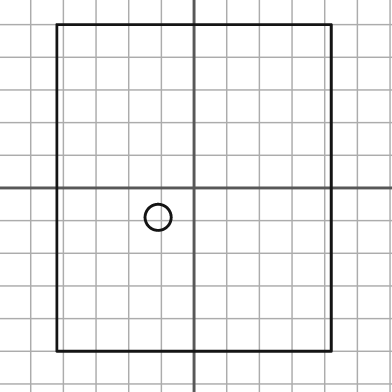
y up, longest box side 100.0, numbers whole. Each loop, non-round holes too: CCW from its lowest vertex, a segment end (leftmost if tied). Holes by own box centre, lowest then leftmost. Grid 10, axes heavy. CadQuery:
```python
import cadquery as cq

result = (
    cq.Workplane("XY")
    .moveTo(-42.0, -50.0)
    .lineTo(42.0, -50.0)
    .lineTo(42.0, 50.0)
    .lineTo(-42.0, 50.0)
    .close()
    .moveTo(-11.0, -9.0)
    .circle(4.0)
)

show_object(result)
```